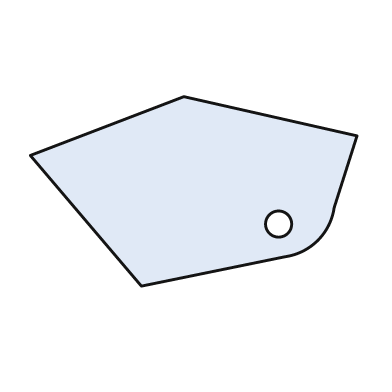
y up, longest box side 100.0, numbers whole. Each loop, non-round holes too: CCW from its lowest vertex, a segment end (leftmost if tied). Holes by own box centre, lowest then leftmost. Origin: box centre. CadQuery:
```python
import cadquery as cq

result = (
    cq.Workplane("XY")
    .moveTo(-16.0, -29.0)
    .lineTo(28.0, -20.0)
    .threePointArc((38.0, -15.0), (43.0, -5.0))
    .lineTo(50.0, 17.0)
    .lineTo(-3.0, 29.0)
    .lineTo(-50.0, 11.0)
    .close()
    .moveTo(26.0, -10.0)
    .circle(4.0)
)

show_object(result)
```